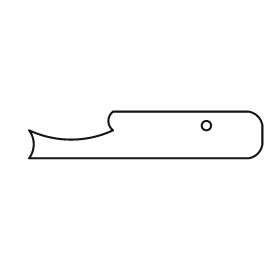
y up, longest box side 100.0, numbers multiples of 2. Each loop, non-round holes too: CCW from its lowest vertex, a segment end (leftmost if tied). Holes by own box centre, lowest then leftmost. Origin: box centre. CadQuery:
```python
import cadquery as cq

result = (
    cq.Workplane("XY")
    .moveTo(-50.0, -10.0)
    .lineTo(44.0, -10.0)
    .threePointArc((48.0, -8.0), (50.0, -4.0))
    .lineTo(50.0, 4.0)
    .threePointArc((48.0, 8.0), (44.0, 10.0))
    .lineTo(-14.0, 10.0)
    .threePointArc((-16.0, 6.0), (-14.0, 2.0))
    .threePointArc((-32.0, -2.0), (-50.0, 2.0))
    .threePointArc((-48.0, -4.0), (-50.0, -10.0))
    .close()
    .moveTo(26.0, 4.0)
    .circle(2.0)
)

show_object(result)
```